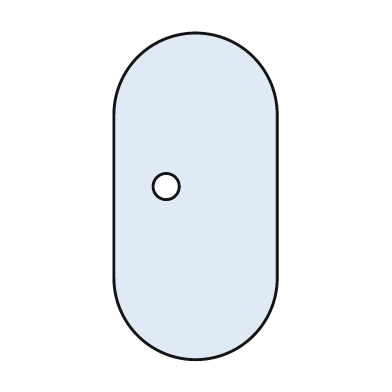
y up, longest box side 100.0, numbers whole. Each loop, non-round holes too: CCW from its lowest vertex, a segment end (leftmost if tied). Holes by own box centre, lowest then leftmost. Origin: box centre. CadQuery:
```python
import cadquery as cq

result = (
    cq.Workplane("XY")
    .moveTo(-25.0, -25.0)
    .threePointArc((0.0, -50.0), (25.0, -25.0))
    .lineTo(25.0, 25.0)
    .threePointArc((0.0, 50.0), (-25.0, 25.0))
    .close()
    .moveTo(-9.0, 3.0)
    .circle(4.0)
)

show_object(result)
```